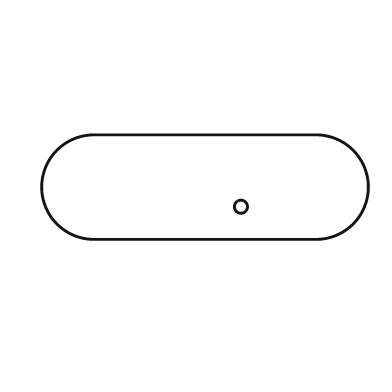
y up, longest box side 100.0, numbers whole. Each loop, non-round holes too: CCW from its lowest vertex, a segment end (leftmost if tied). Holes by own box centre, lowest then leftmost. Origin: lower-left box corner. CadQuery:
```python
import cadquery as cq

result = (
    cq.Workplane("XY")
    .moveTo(16.0, 0.0)
    .lineTo(84.0, 0.0)
    .threePointArc((100.0, 16.0), (84.0, 32.0))
    .lineTo(16.0, 32.0)
    .threePointArc((0.0, 16.0), (16.0, 0.0))
    .close()
    .moveTo(61.0, 10.0)
    .circle(2.0)
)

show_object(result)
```